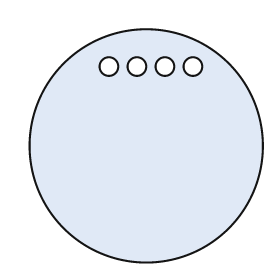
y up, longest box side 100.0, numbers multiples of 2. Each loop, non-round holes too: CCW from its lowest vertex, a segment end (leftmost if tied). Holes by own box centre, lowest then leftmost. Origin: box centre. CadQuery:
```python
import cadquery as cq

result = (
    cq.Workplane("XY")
    .moveTo(0.0, 0.0)
    .circle(50.0)
    .moveTo(-16.0, 34.0)
    .circle(4.0)
    .moveTo(-4.0, 34.0)
    .circle(4.0)
    .moveTo(8.0, 34.0)
    .circle(4.0)
    .moveTo(20.0, 34.0)
    .circle(4.0)
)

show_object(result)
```